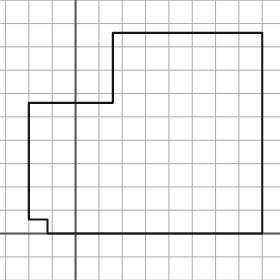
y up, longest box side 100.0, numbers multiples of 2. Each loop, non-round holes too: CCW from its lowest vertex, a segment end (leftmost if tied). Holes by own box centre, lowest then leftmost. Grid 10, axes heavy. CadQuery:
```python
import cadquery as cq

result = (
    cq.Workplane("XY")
    .moveTo(-12.0, 0.0)
    .lineTo(80.0, 0.0)
    .lineTo(80.0, 86.0)
    .lineTo(16.0, 86.0)
    .lineTo(16.0, 56.0)
    .lineTo(-20.0, 56.0)
    .lineTo(-20.0, 6.0)
    .lineTo(-12.0, 6.0)
    .close()
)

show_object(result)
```